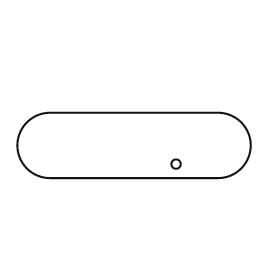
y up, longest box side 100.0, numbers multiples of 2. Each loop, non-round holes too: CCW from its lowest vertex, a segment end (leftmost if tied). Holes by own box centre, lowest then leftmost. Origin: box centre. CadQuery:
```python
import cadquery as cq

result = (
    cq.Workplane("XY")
    .moveTo(-36.0, -14.0)
    .lineTo(36.0, -14.0)
    .threePointArc((50.0, 0.0), (36.0, 14.0))
    .lineTo(-36.0, 14.0)
    .threePointArc((-50.0, 0.0), (-36.0, -14.0))
    .close()
    .moveTo(18.0, -8.0)
    .circle(2.0)
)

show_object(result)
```